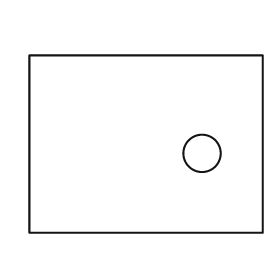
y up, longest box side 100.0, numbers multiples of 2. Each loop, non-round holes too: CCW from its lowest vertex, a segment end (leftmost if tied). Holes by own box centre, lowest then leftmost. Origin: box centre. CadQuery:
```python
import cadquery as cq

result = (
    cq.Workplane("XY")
    .moveTo(-50.0, -38.0)
    .lineTo(50.0, -38.0)
    .lineTo(50.0, 38.0)
    .lineTo(-50.0, 38.0)
    .close()
    .moveTo(24.0, -4.0)
    .circle(8.0)
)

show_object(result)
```